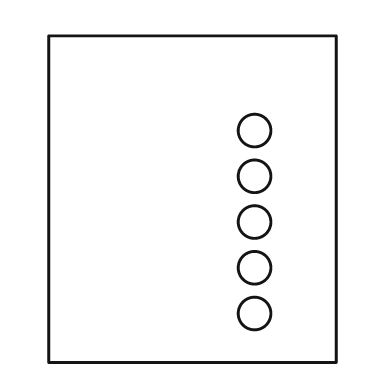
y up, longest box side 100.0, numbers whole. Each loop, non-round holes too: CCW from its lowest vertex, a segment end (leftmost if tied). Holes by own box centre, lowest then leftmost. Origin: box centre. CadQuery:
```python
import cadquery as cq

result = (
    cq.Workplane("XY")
    .moveTo(-44.0, -50.0)
    .lineTo(44.0, -50.0)
    .lineTo(44.0, 50.0)
    .lineTo(-44.0, 50.0)
    .close()
    .moveTo(19.0, -35.0)
    .circle(5.0)
    .moveTo(19.0, -21.0)
    .circle(5.0)
    .moveTo(19.0, -7.0)
    .circle(5.0)
    .moveTo(19.0, 7.0)
    .circle(5.0)
    .moveTo(19.0, 21.0)
    .circle(5.0)
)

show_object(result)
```